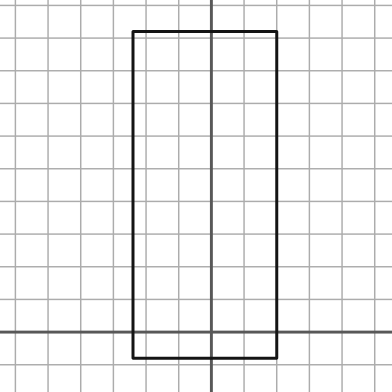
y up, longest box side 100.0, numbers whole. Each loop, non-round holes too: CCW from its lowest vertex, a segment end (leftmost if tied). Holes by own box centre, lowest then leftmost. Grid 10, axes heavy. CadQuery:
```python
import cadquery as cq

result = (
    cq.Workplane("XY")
    .moveTo(-24.0, -8.0)
    .lineTo(20.0, -8.0)
    .lineTo(20.0, 92.0)
    .lineTo(-24.0, 92.0)
    .close()
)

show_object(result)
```